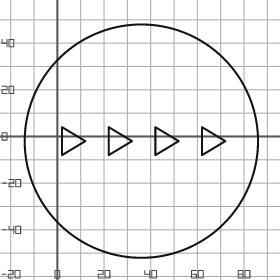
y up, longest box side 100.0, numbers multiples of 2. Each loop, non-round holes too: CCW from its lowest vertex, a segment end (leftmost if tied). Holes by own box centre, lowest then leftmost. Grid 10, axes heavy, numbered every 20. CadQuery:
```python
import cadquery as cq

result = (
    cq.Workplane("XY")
    .moveTo(36.0, -2.0)
    .circle(50.0)
    .moveTo(2.0, -8.0)
    .lineTo(12.0, -2.0)
    .lineTo(2.0, 4.0)
    .close()
    .moveTo(22.0, -8.0)
    .lineTo(32.0, -2.0)
    .lineTo(22.0, 4.0)
    .close()
    .moveTo(42.0, -8.0)
    .lineTo(52.0, -2.0)
    .lineTo(42.0, 4.0)
    .close()
    .moveTo(62.0, -8.0)
    .lineTo(72.0, -2.0)
    .lineTo(62.0, 4.0)
    .close()
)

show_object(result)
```